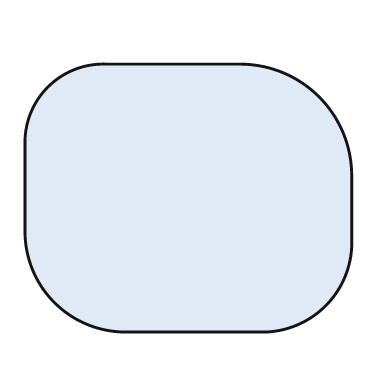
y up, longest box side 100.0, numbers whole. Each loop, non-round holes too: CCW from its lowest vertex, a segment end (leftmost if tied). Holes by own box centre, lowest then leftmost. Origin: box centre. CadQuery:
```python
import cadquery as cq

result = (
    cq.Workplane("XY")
    .moveTo(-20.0, -41.0)
    .lineTo(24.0, -41.0)
    .threePointArc((42.0, -33.0), (50.0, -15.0))
    .lineTo(50.0, 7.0)
    .threePointArc((40.0, 31.0), (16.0, 41.0))
    .lineTo(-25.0, 41.0)
    .threePointArc((-43.0, 34.0), (-50.0, 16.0))
    .lineTo(-50.0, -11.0)
    .threePointArc((-41.0, -32.0), (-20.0, -41.0))
    .close()
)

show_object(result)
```